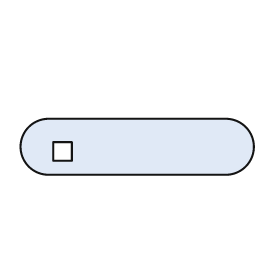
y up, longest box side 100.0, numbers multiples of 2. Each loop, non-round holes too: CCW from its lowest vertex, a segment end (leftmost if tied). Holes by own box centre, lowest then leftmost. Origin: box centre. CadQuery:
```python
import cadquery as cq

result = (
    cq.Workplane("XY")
    .moveTo(-38.0, -12.0)
    .lineTo(38.0, -12.0)
    .threePointArc((50.0, 0.0), (38.0, 12.0))
    .lineTo(-38.0, 12.0)
    .threePointArc((-50.0, 0.0), (-38.0, -12.0))
    .close()
    .moveTo(-36.0, -6.0)
    .lineTo(-28.0, -6.0)
    .lineTo(-28.0, 2.0)
    .lineTo(-36.0, 2.0)
    .close()
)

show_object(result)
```